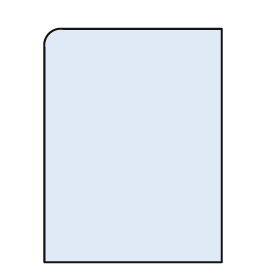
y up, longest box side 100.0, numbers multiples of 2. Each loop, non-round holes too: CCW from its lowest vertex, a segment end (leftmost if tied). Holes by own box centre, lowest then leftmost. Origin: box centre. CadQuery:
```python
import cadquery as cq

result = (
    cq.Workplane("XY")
    .moveTo(-38.0, -50.0)
    .lineTo(38.0, -50.0)
    .lineTo(38.0, 50.0)
    .lineTo(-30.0, 50.0)
    .threePointArc((-36.0, 48.0), (-38.0, 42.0))
    .close()
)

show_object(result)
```